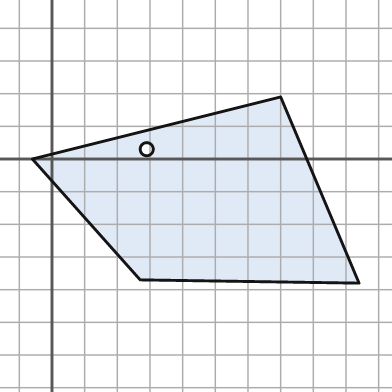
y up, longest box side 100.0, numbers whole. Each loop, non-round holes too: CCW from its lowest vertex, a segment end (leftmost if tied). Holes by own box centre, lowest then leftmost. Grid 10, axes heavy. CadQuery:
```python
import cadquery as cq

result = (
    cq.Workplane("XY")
    .moveTo(94.0, -38.0)
    .lineTo(70.0, 19.0)
    .lineTo(-6.0, 0.0)
    .lineTo(27.0, -37.0)
    .close()
    .moveTo(29.0, 3.0)
    .circle(2.0)
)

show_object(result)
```